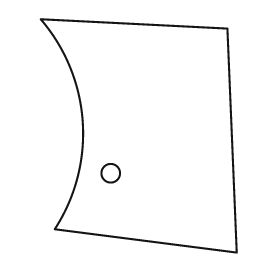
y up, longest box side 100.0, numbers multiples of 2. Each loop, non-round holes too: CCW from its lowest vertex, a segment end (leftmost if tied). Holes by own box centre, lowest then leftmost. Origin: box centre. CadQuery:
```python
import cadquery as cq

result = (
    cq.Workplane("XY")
    .moveTo(42.0, -50.0)
    .lineTo(38.0, 46.0)
    .lineTo(-42.0, 50.0)
    .threePointArc((-24.0, 6.0), (-36.0, -40.0))
    .close()
    .moveTo(-12.0, -16.0)
    .circle(4.0)
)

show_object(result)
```